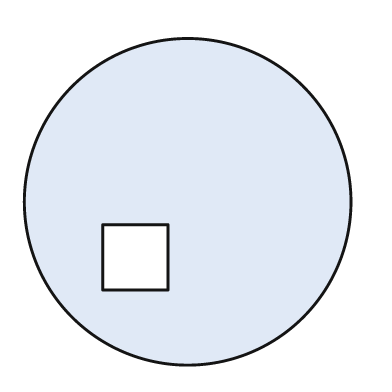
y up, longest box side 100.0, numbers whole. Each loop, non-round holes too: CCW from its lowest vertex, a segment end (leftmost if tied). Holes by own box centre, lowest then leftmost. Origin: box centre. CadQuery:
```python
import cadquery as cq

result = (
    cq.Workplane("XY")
    .moveTo(0.0, 0.0)
    .circle(50.0)
    .moveTo(-26.0, -27.0)
    .lineTo(-6.0, -27.0)
    .lineTo(-6.0, -7.0)
    .lineTo(-26.0, -7.0)
    .close()
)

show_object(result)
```